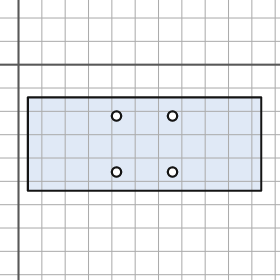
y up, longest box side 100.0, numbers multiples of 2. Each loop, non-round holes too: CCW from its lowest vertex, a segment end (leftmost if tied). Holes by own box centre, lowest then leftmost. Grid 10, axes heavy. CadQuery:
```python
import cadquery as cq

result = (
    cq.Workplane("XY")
    .moveTo(4.0, -54.0)
    .lineTo(104.0, -54.0)
    .lineTo(104.0, -14.0)
    .lineTo(4.0, -14.0)
    .close()
    .moveTo(42.0, -46.0)
    .circle(2.0)
    .moveTo(66.0, -46.0)
    .circle(2.0)
    .moveTo(42.0, -22.0)
    .circle(2.0)
    .moveTo(66.0, -22.0)
    .circle(2.0)
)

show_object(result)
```